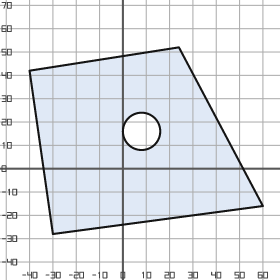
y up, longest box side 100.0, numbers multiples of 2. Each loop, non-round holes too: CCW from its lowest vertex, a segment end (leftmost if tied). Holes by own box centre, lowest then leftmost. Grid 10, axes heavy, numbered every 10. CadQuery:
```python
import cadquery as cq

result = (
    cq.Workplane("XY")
    .moveTo(-30.0, -28.0)
    .lineTo(60.0, -16.0)
    .lineTo(24.0, 52.0)
    .lineTo(-40.0, 42.0)
    .close()
    .moveTo(8.0, 16.0)
    .circle(8.0)
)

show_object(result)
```